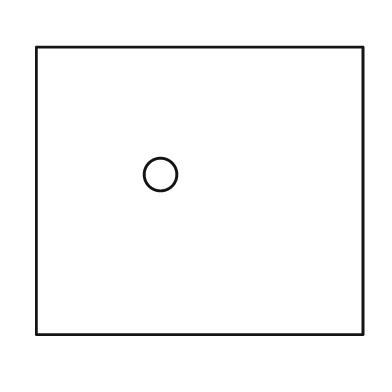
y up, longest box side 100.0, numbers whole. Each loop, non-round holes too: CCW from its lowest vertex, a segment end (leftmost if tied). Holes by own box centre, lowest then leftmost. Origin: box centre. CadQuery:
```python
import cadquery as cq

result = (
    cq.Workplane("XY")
    .moveTo(-50.0, -44.0)
    .lineTo(50.0, -44.0)
    .lineTo(50.0, 44.0)
    .lineTo(-50.0, 44.0)
    .close()
    .moveTo(-12.0, 5.0)
    .circle(5.0)
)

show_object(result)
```